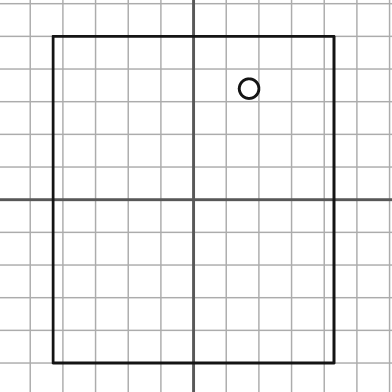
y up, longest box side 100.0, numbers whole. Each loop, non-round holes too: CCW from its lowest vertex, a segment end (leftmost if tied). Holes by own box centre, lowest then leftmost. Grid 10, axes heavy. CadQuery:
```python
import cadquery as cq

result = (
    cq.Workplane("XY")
    .moveTo(-43.0, -50.0)
    .lineTo(43.0, -50.0)
    .lineTo(43.0, 50.0)
    .lineTo(-43.0, 50.0)
    .close()
    .moveTo(17.0, 34.0)
    .circle(3.0)
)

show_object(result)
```